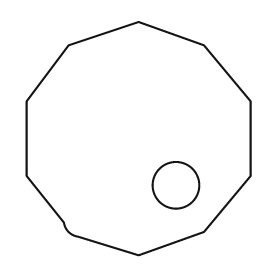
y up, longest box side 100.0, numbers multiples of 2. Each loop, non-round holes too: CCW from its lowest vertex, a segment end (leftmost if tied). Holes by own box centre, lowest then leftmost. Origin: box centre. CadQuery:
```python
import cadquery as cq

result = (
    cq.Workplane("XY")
    .moveTo(0.0, -50.0)
    .lineTo(28.0, -40.0)
    .lineTo(48.0, -16.0)
    .lineTo(48.0, 16.0)
    .lineTo(28.0, 40.0)
    .lineTo(0.0, 50.0)
    .lineTo(-30.0, 40.0)
    .lineTo(-48.0, 16.0)
    .lineTo(-48.0, -16.0)
    .lineTo(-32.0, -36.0)
    .threePointArc((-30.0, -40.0), (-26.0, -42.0))
    .close()
    .moveTo(16.0, -20.0)
    .circle(10.0)
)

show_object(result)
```